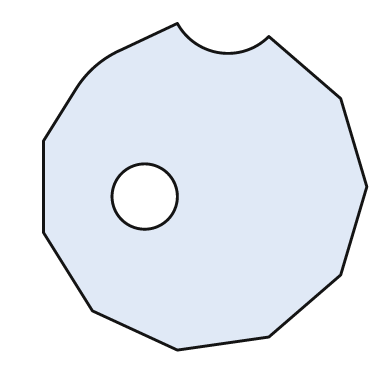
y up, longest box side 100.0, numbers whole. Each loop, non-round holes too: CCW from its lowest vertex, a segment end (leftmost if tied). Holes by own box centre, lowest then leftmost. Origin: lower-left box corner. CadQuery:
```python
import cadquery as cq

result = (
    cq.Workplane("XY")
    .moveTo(41.0, 0.0)
    .lineTo(69.0, 4.0)
    .lineTo(91.0, 23.0)
    .lineTo(99.0, 50.0)
    .lineTo(91.0, 77.0)
    .lineTo(69.0, 96.0)
    .threePointArc((54.0, 91.0), (41.0, 100.0))
    .lineTo(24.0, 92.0)
    .threePointArc((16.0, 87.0), (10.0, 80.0))
    .lineTo(0.0, 64.0)
    .lineTo(0.0, 36.0)
    .lineTo(15.0, 12.0)
    .close()
    .moveTo(31.0, 47.0)
    .circle(10.0)
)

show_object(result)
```